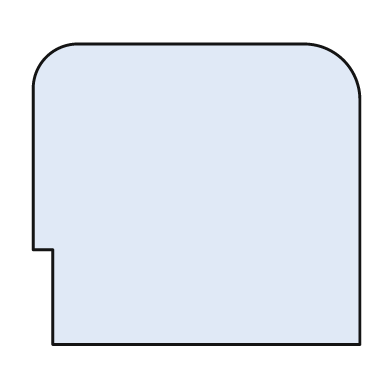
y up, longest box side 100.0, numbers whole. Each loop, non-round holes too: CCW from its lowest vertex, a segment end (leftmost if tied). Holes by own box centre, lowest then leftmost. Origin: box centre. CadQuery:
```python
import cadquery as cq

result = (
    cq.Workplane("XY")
    .moveTo(-44.0, -46.0)
    .lineTo(50.0, -46.0)
    .lineTo(50.0, 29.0)
    .threePointArc((45.0, 41.0), (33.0, 46.0))
    .lineTo(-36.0, 46.0)
    .threePointArc((-46.0, 42.0), (-50.0, 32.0))
    .lineTo(-50.0, -17.0)
    .lineTo(-44.0, -17.0)
    .close()
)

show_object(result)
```